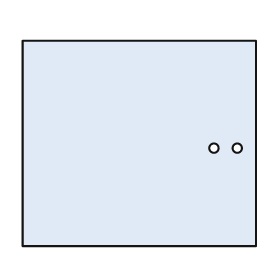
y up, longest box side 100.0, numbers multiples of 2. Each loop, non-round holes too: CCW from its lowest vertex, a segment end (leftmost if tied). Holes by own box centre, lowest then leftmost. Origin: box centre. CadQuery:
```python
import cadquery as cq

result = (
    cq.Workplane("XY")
    .moveTo(-50.0, -44.0)
    .lineTo(50.0, -44.0)
    .lineTo(50.0, 44.0)
    .lineTo(-50.0, 44.0)
    .close()
    .moveTo(32.0, -2.0)
    .circle(2.0)
    .moveTo(42.0, -2.0)
    .circle(2.0)
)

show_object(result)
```